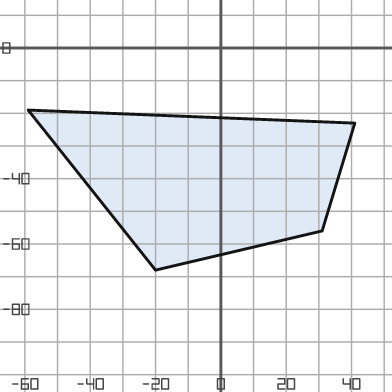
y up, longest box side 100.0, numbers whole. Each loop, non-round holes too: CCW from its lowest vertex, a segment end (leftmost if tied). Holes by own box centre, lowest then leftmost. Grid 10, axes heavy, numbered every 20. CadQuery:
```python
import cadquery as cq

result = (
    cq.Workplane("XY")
    .moveTo(-20.0, -68.0)
    .lineTo(31.0, -56.0)
    .lineTo(41.0, -23.0)
    .lineTo(-59.0, -19.0)
    .close()
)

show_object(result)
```